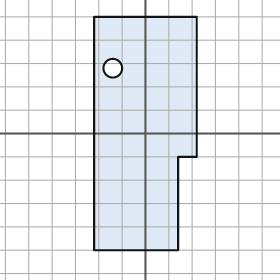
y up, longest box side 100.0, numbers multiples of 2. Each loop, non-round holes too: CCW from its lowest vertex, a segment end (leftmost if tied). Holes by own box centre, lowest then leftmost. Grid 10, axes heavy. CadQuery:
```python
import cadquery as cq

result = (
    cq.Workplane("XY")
    .moveTo(-22.0, -50.0)
    .lineTo(14.0, -50.0)
    .lineTo(14.0, -10.0)
    .lineTo(22.0, -10.0)
    .lineTo(22.0, 50.0)
    .lineTo(-22.0, 50.0)
    .close()
    .moveTo(-14.0, 28.0)
    .circle(4.0)
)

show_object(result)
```